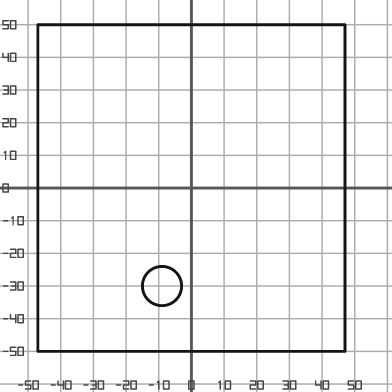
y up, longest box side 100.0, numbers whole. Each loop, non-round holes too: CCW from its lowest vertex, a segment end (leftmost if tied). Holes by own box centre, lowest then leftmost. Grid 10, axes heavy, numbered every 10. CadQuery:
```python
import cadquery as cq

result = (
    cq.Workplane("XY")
    .moveTo(-47.0, -50.0)
    .lineTo(47.0, -50.0)
    .lineTo(47.0, 50.0)
    .lineTo(-47.0, 50.0)
    .close()
    .moveTo(-9.0, -30.0)
    .circle(6.0)
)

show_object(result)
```